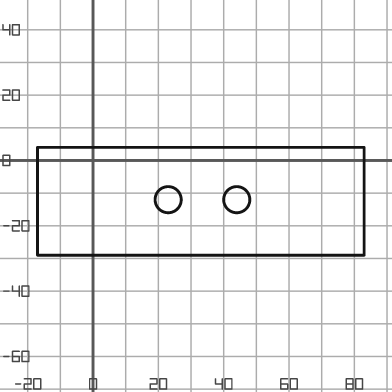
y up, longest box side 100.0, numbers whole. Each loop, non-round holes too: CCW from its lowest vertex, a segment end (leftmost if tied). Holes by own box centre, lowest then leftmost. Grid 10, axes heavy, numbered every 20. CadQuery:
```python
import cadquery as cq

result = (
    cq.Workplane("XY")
    .moveTo(-17.0, -29.0)
    .lineTo(83.0, -29.0)
    .lineTo(83.0, 4.0)
    .lineTo(-17.0, 4.0)
    .close()
    .moveTo(23.0, -12.0)
    .circle(4.0)
    .moveTo(44.0, -12.0)
    .circle(4.0)
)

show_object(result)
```